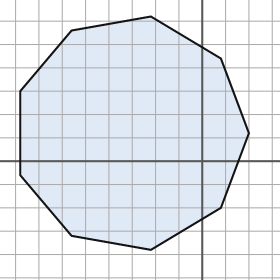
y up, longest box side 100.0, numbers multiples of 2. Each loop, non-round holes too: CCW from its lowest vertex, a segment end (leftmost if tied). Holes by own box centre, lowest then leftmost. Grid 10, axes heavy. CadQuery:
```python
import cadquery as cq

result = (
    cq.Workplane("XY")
    .moveTo(-22.0, -38.0)
    .lineTo(8.0, -20.0)
    .lineTo(20.0, 12.0)
    .lineTo(8.0, 44.0)
    .lineTo(-22.0, 62.0)
    .lineTo(-56.0, 56.0)
    .lineTo(-78.0, 30.0)
    .lineTo(-78.0, -6.0)
    .lineTo(-56.0, -32.0)
    .close()
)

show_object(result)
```